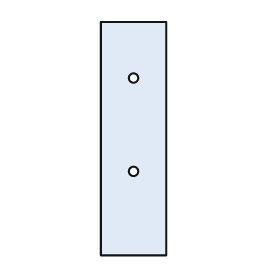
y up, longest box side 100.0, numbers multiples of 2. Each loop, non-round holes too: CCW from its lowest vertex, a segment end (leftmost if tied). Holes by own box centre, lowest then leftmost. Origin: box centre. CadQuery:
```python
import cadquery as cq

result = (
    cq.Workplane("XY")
    .moveTo(-14.0, -50.0)
    .lineTo(14.0, -50.0)
    .lineTo(14.0, 50.0)
    .lineTo(-14.0, 50.0)
    .close()
    .moveTo(0.0, -14.0)
    .circle(2.0)
    .moveTo(0.0, 26.0)
    .circle(2.0)
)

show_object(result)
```